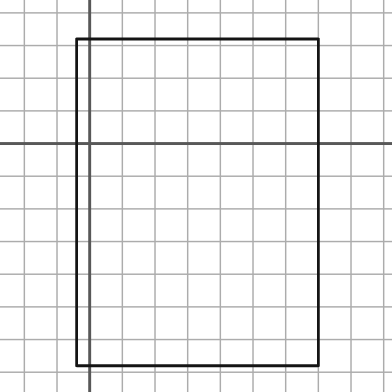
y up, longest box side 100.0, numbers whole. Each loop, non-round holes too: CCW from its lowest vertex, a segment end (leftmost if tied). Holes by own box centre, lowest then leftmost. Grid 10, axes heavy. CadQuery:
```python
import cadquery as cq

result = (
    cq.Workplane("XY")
    .moveTo(-4.0, -68.0)
    .lineTo(70.0, -68.0)
    .lineTo(70.0, 32.0)
    .lineTo(-4.0, 32.0)
    .close()
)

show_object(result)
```